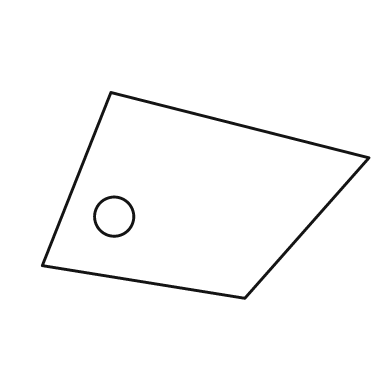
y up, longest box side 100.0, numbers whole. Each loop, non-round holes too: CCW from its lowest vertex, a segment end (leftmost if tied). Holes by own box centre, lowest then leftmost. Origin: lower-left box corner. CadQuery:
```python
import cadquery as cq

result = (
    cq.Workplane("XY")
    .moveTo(62.0, 0.0)
    .lineTo(100.0, 43.0)
    .lineTo(21.0, 63.0)
    .lineTo(0.0, 10.0)
    .close()
    .moveTo(22.0, 25.0)
    .circle(6.0)
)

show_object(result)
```